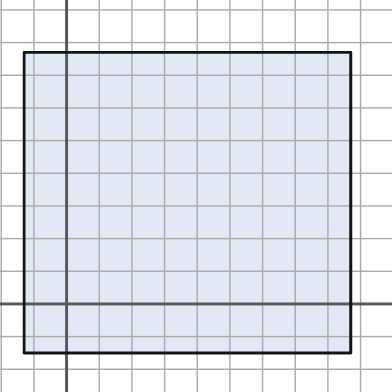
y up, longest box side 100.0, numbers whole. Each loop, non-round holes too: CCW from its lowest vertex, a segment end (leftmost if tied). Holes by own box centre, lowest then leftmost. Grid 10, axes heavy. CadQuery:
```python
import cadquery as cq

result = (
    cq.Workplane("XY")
    .moveTo(-13.0, -15.0)
    .lineTo(87.0, -15.0)
    .lineTo(87.0, 77.0)
    .lineTo(-13.0, 77.0)
    .close()
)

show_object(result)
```